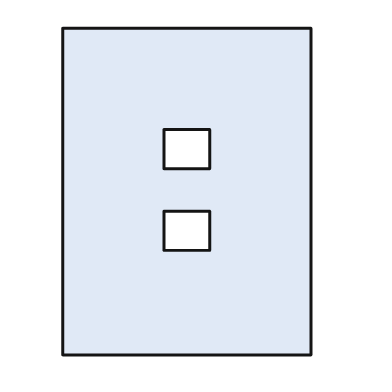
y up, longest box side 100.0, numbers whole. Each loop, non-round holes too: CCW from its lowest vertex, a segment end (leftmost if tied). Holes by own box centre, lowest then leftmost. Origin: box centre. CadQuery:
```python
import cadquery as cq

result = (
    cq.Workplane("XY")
    .moveTo(-38.0, -50.0)
    .lineTo(38.0, -50.0)
    .lineTo(38.0, 50.0)
    .lineTo(-38.0, 50.0)
    .close()
    .moveTo(-7.0, -18.0)
    .lineTo(7.0, -18.0)
    .lineTo(7.0, -6.0)
    .lineTo(-7.0, -6.0)
    .close()
    .moveTo(-7.0, 7.0)
    .lineTo(7.0, 7.0)
    .lineTo(7.0, 19.0)
    .lineTo(-7.0, 19.0)
    .close()
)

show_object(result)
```